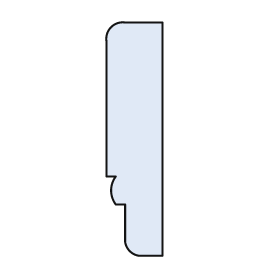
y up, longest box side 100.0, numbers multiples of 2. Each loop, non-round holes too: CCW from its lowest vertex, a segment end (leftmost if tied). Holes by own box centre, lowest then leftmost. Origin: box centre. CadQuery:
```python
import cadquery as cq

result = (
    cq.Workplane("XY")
    .moveTo(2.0, -50.0)
    .lineTo(12.0, -50.0)
    .lineTo(12.0, 50.0)
    .lineTo(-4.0, 50.0)
    .threePointArc((-10.0, 48.0), (-12.0, 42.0))
    .lineTo(-12.0, -16.0)
    .lineTo(-8.0, -16.0)
    .threePointArc((-10.0, -22.0), (-8.0, -28.0))
    .lineTo(-4.0, -28.0)
    .lineTo(-4.0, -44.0)
    .threePointArc((-2.0, -48.0), (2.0, -50.0))
    .close()
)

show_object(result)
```